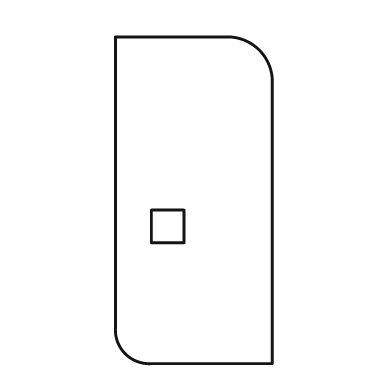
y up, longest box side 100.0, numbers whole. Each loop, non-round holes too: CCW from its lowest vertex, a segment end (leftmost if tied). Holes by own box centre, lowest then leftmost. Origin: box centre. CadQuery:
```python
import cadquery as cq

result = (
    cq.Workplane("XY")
    .moveTo(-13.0, -50.0)
    .lineTo(24.0, -50.0)
    .lineTo(24.0, 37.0)
    .threePointArc((20.0, 46.0), (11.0, 50.0))
    .lineTo(-24.0, 50.0)
    .lineTo(-24.0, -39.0)
    .threePointArc((-21.0, -47.0), (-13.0, -50.0))
    .close()
    .moveTo(-13.0, -13.0)
    .lineTo(-3.0, -13.0)
    .lineTo(-3.0, -3.0)
    .lineTo(-13.0, -3.0)
    .close()
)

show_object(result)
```